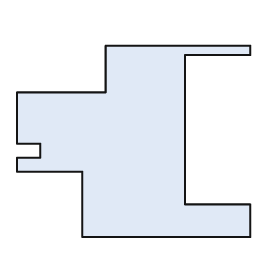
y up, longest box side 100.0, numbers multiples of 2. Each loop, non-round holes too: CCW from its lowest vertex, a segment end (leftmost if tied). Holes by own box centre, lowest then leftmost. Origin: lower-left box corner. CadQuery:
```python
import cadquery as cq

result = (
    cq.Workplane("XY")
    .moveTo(28.0, 0.0)
    .lineTo(100.0, 0.0)
    .lineTo(100.0, 14.0)
    .lineTo(72.0, 14.0)
    .lineTo(72.0, 78.0)
    .lineTo(100.0, 78.0)
    .lineTo(100.0, 82.0)
    .lineTo(38.0, 82.0)
    .lineTo(38.0, 62.0)
    .lineTo(0.0, 62.0)
    .lineTo(0.0, 40.0)
    .lineTo(10.0, 40.0)
    .lineTo(10.0, 34.0)
    .lineTo(0.0, 34.0)
    .lineTo(0.0, 28.0)
    .lineTo(28.0, 28.0)
    .close()
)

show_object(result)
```